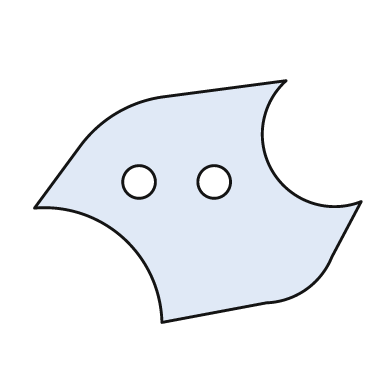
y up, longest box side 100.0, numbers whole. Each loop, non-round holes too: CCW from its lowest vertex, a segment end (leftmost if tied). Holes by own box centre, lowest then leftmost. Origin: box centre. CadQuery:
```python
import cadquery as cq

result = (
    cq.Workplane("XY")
    .moveTo(-11.0, -37.0)
    .lineTo(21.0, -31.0)
    .threePointArc((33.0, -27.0), (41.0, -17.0))
    .lineTo(50.0, 0.0)
    .threePointArc((23.0, 9.0), (27.0, 37.0))
    .lineTo(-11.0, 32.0)
    .threePointArc((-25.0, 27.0), (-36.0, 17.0))
    .lineTo(-50.0, -2.0)
    .threePointArc((-23.0, -11.0), (-11.0, -37.0))
    .close()
    .moveTo(-18.0, 6.0)
    .circle(5.0)
    .moveTo(5.0, 6.0)
    .circle(5.0)
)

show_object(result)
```